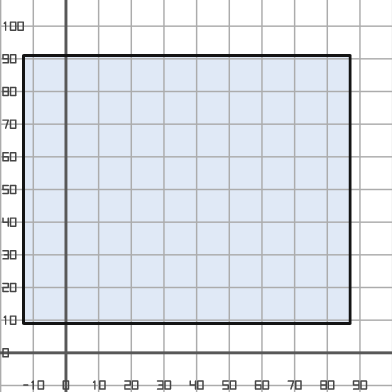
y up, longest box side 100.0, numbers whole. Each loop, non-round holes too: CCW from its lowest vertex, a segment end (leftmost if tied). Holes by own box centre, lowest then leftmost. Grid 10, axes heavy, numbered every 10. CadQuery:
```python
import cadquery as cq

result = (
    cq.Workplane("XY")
    .moveTo(-13.0, 9.0)
    .lineTo(87.0, 9.0)
    .lineTo(87.0, 91.0)
    .lineTo(-13.0, 91.0)
    .close()
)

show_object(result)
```